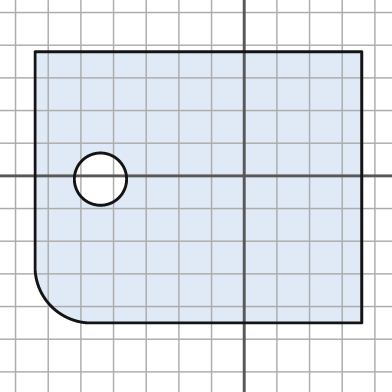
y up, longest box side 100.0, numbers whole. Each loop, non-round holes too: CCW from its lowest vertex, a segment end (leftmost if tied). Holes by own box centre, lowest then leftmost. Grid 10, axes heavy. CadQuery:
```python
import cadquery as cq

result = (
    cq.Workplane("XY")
    .moveTo(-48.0, -45.0)
    .lineTo(36.0, -45.0)
    .lineTo(36.0, 38.0)
    .lineTo(-64.0, 38.0)
    .lineTo(-64.0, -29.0)
    .threePointArc((-59.0, -40.0), (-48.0, -45.0))
    .close()
    .moveTo(-44.0, -1.0)
    .circle(8.0)
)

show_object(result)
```